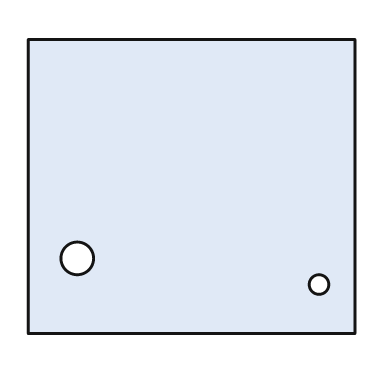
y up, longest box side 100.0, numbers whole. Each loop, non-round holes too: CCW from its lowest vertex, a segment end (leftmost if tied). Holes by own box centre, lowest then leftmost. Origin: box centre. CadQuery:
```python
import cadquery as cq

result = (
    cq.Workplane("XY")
    .moveTo(-50.0, -45.0)
    .lineTo(50.0, -45.0)
    .lineTo(50.0, 45.0)
    .lineTo(-50.0, 45.0)
    .close()
    .moveTo(39.0, -30.0)
    .circle(3.0)
    .moveTo(-35.0, -22.0)
    .circle(5.0)
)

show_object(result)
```